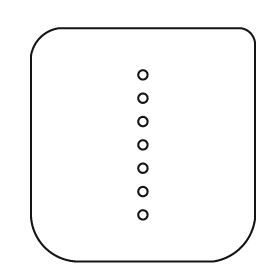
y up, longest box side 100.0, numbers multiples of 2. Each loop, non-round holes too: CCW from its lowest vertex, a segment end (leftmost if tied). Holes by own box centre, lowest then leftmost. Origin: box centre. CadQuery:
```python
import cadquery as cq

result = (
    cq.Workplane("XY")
    .moveTo(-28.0, -50.0)
    .lineTo(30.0, -50.0)
    .threePointArc((42.0, -44.0), (48.0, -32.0))
    .lineTo(48.0, 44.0)
    .threePointArc((46.0, 48.0), (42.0, 50.0))
    .lineTo(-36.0, 50.0)
    .threePointArc((-44.0, 46.0), (-48.0, 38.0))
    .lineTo(-48.0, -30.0)
    .threePointArc((-42.0, -44.0), (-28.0, -50.0))
    .close()
    .moveTo(0.0, -30.0)
    .circle(2.0)
    .moveTo(0.0, -20.0)
    .circle(2.0)
    .moveTo(0.0, -10.0)
    .circle(2.0)
    .moveTo(0.0, 0.0)
    .circle(2.0)
    .moveTo(0.0, 10.0)
    .circle(2.0)
    .moveTo(0.0, 20.0)
    .circle(2.0)
    .moveTo(0.0, 30.0)
    .circle(2.0)
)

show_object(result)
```